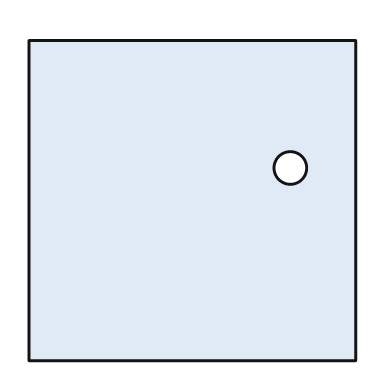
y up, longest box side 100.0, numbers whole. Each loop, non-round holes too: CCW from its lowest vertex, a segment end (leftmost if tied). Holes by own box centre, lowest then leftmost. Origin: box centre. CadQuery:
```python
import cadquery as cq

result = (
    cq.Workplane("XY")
    .moveTo(-50.0, -49.0)
    .lineTo(50.0, -49.0)
    .lineTo(50.0, 49.0)
    .lineTo(-50.0, 49.0)
    .close()
    .moveTo(30.0, 10.0)
    .circle(5.0)
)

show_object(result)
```